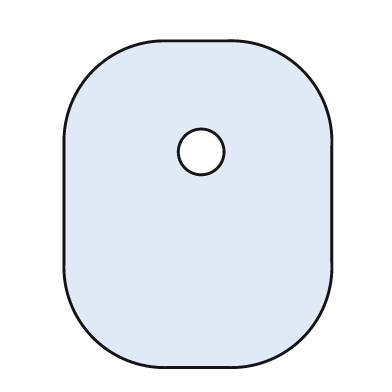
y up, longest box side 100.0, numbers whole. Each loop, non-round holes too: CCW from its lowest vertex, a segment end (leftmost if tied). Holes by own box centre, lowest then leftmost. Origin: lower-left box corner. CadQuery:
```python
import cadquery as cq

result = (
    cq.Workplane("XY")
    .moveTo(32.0, 0.0)
    .lineTo(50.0, 0.0)
    .threePointArc((73.0, 9.0), (82.0, 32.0))
    .lineTo(82.0, 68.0)
    .threePointArc((73.0, 91.0), (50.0, 100.0))
    .lineTo(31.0, 100.0)
    .threePointArc((9.0, 91.0), (0.0, 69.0))
    .lineTo(0.0, 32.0)
    .threePointArc((9.0, 9.0), (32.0, 0.0))
    .close()
    .moveTo(42.0, 66.0)
    .circle(7.0)
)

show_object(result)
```